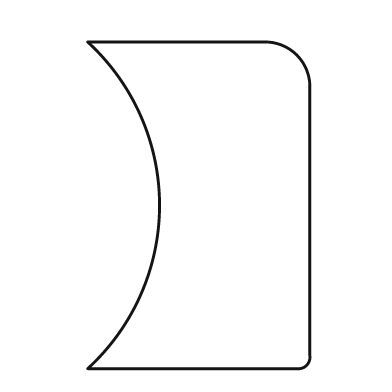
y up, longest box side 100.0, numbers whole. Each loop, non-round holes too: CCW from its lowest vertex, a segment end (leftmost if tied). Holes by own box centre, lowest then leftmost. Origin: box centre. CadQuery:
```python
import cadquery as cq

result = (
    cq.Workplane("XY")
    .moveTo(-34.0, -50.0)
    .lineTo(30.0, -50.0)
    .threePointArc((33.0, -49.0), (34.0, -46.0))
    .lineTo(34.0, 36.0)
    .threePointArc((30.0, 46.0), (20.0, 50.0))
    .lineTo(-34.0, 50.0)
    .threePointArc((-12.0, 0.0), (-34.0, -50.0))
    .close()
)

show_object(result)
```